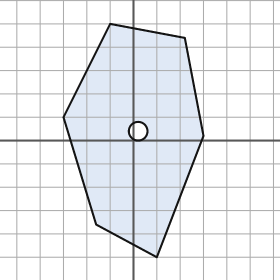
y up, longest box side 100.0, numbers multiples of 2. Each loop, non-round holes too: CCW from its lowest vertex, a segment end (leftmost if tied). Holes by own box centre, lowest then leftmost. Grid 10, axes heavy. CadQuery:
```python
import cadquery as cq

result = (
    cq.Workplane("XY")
    .moveTo(10.0, -50.0)
    .lineTo(30.0, 2.0)
    .lineTo(22.0, 44.0)
    .lineTo(-10.0, 50.0)
    .lineTo(-30.0, 10.0)
    .lineTo(-16.0, -36.0)
    .close()
    .moveTo(2.0, 4.0)
    .circle(4.0)
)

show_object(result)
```